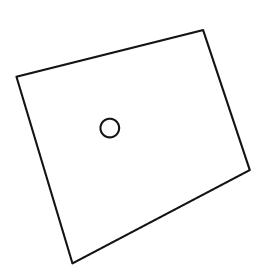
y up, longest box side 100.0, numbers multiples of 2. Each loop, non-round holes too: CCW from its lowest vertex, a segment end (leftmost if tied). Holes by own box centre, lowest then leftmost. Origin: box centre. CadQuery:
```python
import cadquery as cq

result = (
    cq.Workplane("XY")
    .moveTo(-26.0, -50.0)
    .lineTo(50.0, -10.0)
    .lineTo(30.0, 50.0)
    .lineTo(-50.0, 30.0)
    .close()
    .moveTo(-10.0, 8.0)
    .circle(4.0)
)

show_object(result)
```